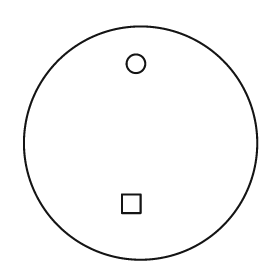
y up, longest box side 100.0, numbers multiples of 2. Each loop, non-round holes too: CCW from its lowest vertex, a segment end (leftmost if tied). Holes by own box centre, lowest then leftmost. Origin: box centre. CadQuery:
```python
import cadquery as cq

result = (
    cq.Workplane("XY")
    .moveTo(0.0, 0.0)
    .circle(50.0)
    .moveTo(-8.0, -30.0)
    .lineTo(0.0, -30.0)
    .lineTo(0.0, -22.0)
    .lineTo(-8.0, -22.0)
    .close()
    .moveTo(-2.0, 34.0)
    .circle(4.0)
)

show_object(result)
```